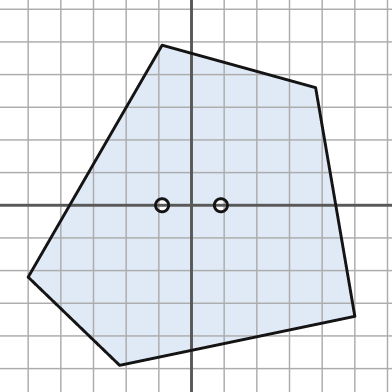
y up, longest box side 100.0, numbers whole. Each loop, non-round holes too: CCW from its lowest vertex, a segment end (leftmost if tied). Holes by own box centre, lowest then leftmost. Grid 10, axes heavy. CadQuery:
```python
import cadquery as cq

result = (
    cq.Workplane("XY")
    .moveTo(-22.0, -49.0)
    .lineTo(50.0, -34.0)
    .lineTo(38.0, 36.0)
    .lineTo(-9.0, 49.0)
    .lineTo(-50.0, -22.0)
    .close()
    .moveTo(-9.0, 0.0)
    .circle(2.0)
    .moveTo(9.0, 0.0)
    .circle(2.0)
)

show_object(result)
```